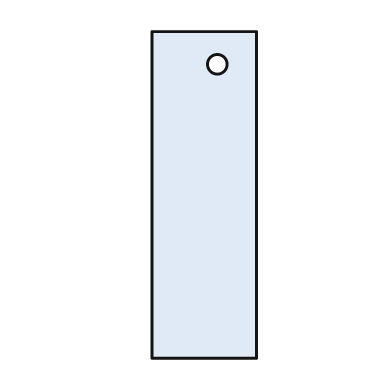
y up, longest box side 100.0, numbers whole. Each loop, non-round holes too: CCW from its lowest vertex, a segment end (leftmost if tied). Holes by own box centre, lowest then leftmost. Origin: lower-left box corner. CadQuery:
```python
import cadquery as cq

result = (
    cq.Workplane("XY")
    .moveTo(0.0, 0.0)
    .lineTo(32.0, 0.0)
    .lineTo(32.0, 100.0)
    .lineTo(0.0, 100.0)
    .close()
    .moveTo(20.0, 90.0)
    .circle(3.0)
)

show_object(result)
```